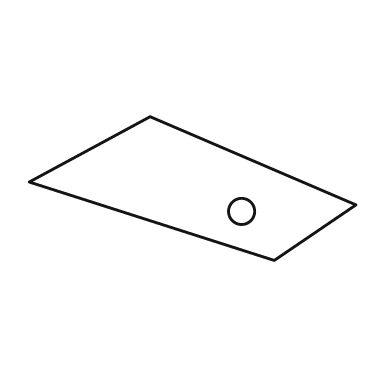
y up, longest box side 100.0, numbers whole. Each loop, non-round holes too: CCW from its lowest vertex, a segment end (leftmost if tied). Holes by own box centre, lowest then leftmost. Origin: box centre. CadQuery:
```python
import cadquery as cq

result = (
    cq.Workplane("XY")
    .moveTo(25.0, -22.0)
    .lineTo(50.0, -5.0)
    .lineTo(-13.0, 22.0)
    .lineTo(-50.0, 2.0)
    .close()
    .moveTo(15.0, -7.0)
    .circle(4.0)
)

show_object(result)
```